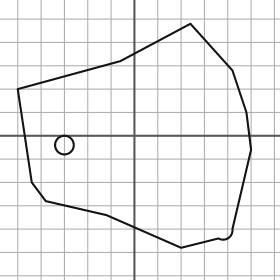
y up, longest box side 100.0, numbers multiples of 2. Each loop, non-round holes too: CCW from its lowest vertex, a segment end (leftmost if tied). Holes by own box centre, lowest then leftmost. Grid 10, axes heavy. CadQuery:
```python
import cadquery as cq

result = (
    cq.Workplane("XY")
    .moveTo(20.0, -48.0)
    .lineTo(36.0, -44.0)
    .threePointArc((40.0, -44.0), (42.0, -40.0))
    .lineTo(50.0, -6.0)
    .lineTo(48.0, 10.0)
    .lineTo(42.0, 28.0)
    .lineTo(24.0, 48.0)
    .lineTo(-6.0, 32.0)
    .lineTo(-50.0, 20.0)
    .lineTo(-44.0, -20.0)
    .lineTo(-38.0, -28.0)
    .lineTo(-12.0, -34.0)
    .close()
    .moveTo(-30.0, -4.0)
    .circle(4.0)
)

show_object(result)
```